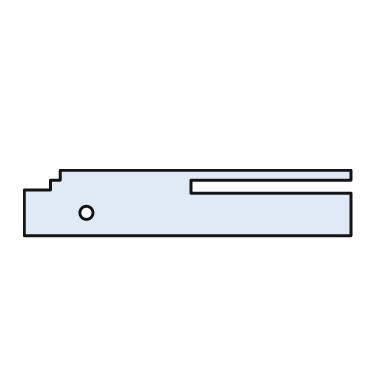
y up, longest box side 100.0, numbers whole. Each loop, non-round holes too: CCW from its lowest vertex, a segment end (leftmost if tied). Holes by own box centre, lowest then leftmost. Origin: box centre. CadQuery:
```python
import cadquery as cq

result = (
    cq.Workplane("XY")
    .moveTo(-50.0, -10.0)
    .lineTo(50.0, -10.0)
    .lineTo(50.0, 3.0)
    .lineTo(1.0, 3.0)
    .lineTo(1.0, 7.0)
    .lineTo(50.0, 7.0)
    .lineTo(50.0, 10.0)
    .lineTo(-39.0, 10.0)
    .lineTo(-39.0, 7.0)
    .lineTo(-42.0, 7.0)
    .lineTo(-42.0, 4.0)
    .lineTo(-50.0, 4.0)
    .close()
    .moveTo(-31.0, -3.0)
    .circle(2.0)
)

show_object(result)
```